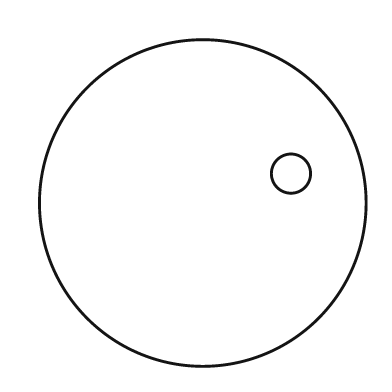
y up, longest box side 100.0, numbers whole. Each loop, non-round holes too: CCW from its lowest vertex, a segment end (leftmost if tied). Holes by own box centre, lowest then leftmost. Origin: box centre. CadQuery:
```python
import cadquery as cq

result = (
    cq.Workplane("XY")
    .moveTo(0.0, 0.0)
    .circle(50.0)
    .moveTo(27.0, 9.0)
    .circle(6.0)
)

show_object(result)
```